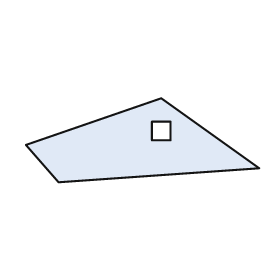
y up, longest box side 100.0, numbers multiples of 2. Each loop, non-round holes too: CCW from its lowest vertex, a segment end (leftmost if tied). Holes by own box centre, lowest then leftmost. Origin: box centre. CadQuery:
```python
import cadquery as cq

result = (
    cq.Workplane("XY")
    .moveTo(-36.0, -18.0)
    .lineTo(50.0, -12.0)
    .lineTo(8.0, 18.0)
    .lineTo(-50.0, -2.0)
    .close()
    .moveTo(4.0, 0.0)
    .lineTo(12.0, 0.0)
    .lineTo(12.0, 8.0)
    .lineTo(4.0, 8.0)
    .close()
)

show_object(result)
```